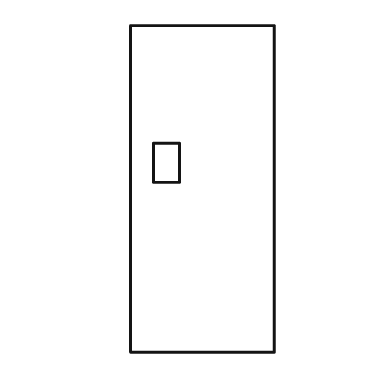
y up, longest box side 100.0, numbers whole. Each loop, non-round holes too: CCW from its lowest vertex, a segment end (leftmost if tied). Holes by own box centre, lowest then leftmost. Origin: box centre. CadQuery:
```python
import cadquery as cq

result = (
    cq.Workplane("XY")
    .moveTo(-22.0, -50.0)
    .lineTo(22.0, -50.0)
    .lineTo(22.0, 50.0)
    .lineTo(-22.0, 50.0)
    .close()
    .moveTo(-15.0, 2.0)
    .lineTo(-7.0, 2.0)
    .lineTo(-7.0, 14.0)
    .lineTo(-15.0, 14.0)
    .close()
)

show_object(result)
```